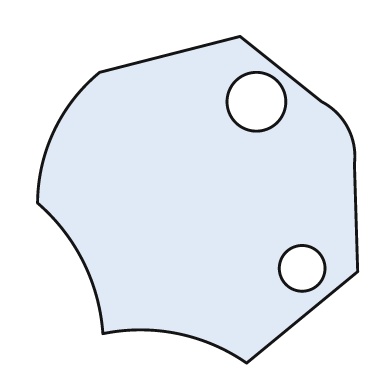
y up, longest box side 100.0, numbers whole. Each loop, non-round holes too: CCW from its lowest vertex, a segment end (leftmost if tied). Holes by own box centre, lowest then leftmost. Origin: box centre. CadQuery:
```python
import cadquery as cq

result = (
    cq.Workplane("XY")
    .moveTo(15.0, -50.0)
    .lineTo(49.0, -22.0)
    .lineTo(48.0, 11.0)
    .threePointArc((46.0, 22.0), (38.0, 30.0))
    .lineTo(13.0, 50.0)
    .lineTo(-30.0, 39.0)
    .threePointArc((-44.0, 21.0), (-49.0, -1.0))
    .threePointArc((-35.0, -19.0), (-29.0, -41.0))
    .threePointArc((-6.0, -41.0), (15.0, -50.0))
    .close()
    .moveTo(32.0, -21.0)
    .circle(7.0)
    .moveTo(18.0, 30.0)
    .circle(9.0)
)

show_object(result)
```